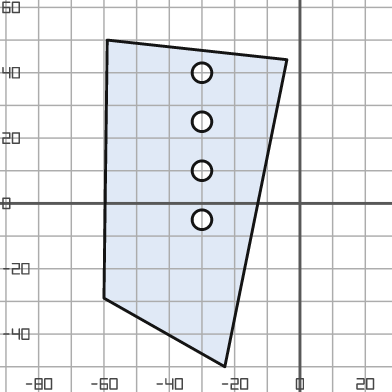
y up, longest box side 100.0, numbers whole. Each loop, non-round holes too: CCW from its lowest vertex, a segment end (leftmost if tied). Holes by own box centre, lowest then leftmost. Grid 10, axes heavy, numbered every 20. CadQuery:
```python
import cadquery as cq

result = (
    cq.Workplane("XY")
    .moveTo(-23.0, -50.0)
    .lineTo(-4.0, 44.0)
    .lineTo(-59.0, 50.0)
    .lineTo(-60.0, -29.0)
    .close()
    .moveTo(-30.0, -5.0)
    .circle(3.0)
    .moveTo(-30.0, 10.0)
    .circle(3.0)
    .moveTo(-30.0, 25.0)
    .circle(3.0)
    .moveTo(-30.0, 40.0)
    .circle(3.0)
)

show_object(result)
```